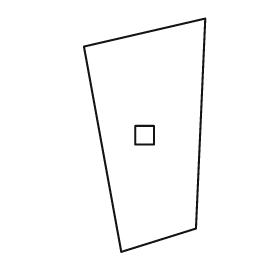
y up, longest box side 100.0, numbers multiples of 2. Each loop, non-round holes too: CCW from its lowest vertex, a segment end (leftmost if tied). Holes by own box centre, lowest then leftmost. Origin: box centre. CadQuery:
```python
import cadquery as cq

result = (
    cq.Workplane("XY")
    .moveTo(-10.0, -50.0)
    .lineTo(22.0, -40.0)
    .lineTo(26.0, 50.0)
    .lineTo(-26.0, 38.0)
    .close()
    .moveTo(-4.0, -4.0)
    .lineTo(4.0, -4.0)
    .lineTo(4.0, 4.0)
    .lineTo(-4.0, 4.0)
    .close()
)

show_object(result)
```